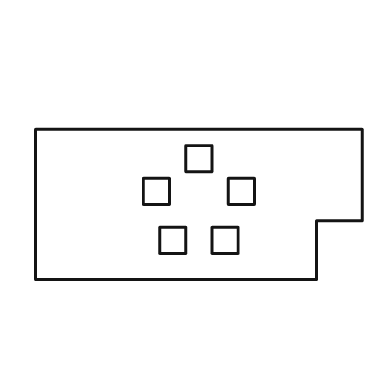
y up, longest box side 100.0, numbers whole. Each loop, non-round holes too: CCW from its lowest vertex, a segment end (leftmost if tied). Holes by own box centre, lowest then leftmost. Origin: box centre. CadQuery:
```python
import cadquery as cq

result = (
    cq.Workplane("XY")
    .moveTo(-50.0, -23.0)
    .lineTo(36.0, -23.0)
    .lineTo(36.0, -5.0)
    .lineTo(50.0, -5.0)
    .lineTo(50.0, 23.0)
    .lineTo(-50.0, 23.0)
    .close()
    .moveTo(-12.0, -15.0)
    .lineTo(-4.0, -15.0)
    .lineTo(-4.0, -7.0)
    .lineTo(-12.0, -7.0)
    .close()
    .moveTo(4.0, -15.0)
    .lineTo(12.0, -15.0)
    .lineTo(12.0, -7.0)
    .lineTo(4.0, -7.0)
    .close()
    .moveTo(-17.0, 0.0)
    .lineTo(-9.0, 0.0)
    .lineTo(-9.0, 8.0)
    .lineTo(-17.0, 8.0)
    .close()
    .moveTo(9.0, 0.0)
    .lineTo(17.0, 0.0)
    .lineTo(17.0, 8.0)
    .lineTo(9.0, 8.0)
    .close()
    .moveTo(-4.0, 10.0)
    .lineTo(4.0, 10.0)
    .lineTo(4.0, 18.0)
    .lineTo(-4.0, 18.0)
    .close()
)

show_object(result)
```